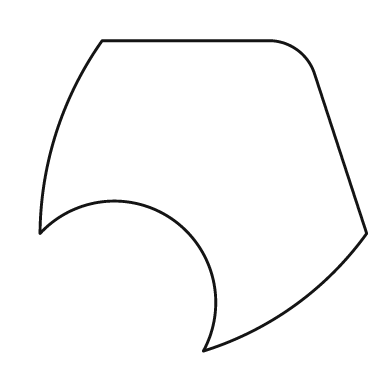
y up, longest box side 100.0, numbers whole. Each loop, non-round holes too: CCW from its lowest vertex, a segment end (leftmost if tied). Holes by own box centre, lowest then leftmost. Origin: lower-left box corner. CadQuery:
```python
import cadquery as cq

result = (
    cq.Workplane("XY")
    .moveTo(50.0, 0.0)
    .threePointArc((78.0, 14.0), (100.0, 36.0))
    .lineTo(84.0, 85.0)
    .threePointArc((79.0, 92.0), (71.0, 95.0))
    .lineTo(19.0, 95.0)
    .threePointArc((5.0, 67.0), (0.0, 36.0))
    .threePointArc((41.0, 40.0), (50.0, 0.0))
    .close()
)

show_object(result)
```